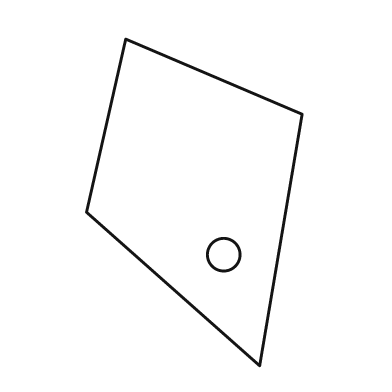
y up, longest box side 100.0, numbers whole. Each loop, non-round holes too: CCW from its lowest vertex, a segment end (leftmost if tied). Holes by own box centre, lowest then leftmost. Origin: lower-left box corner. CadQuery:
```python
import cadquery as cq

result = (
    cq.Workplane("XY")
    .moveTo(53.0, 0.0)
    .lineTo(66.0, 77.0)
    .lineTo(12.0, 100.0)
    .lineTo(0.0, 47.0)
    .close()
    .moveTo(42.0, 34.0)
    .circle(5.0)
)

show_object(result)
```